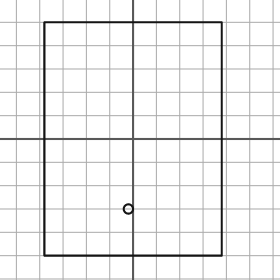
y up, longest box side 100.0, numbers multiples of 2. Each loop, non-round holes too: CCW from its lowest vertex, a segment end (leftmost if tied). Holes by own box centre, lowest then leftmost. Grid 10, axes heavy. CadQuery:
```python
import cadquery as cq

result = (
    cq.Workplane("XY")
    .moveTo(-38.0, -50.0)
    .lineTo(38.0, -50.0)
    .lineTo(38.0, 50.0)
    .lineTo(-38.0, 50.0)
    .close()
    .moveTo(-2.0, -30.0)
    .circle(2.0)
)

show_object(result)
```